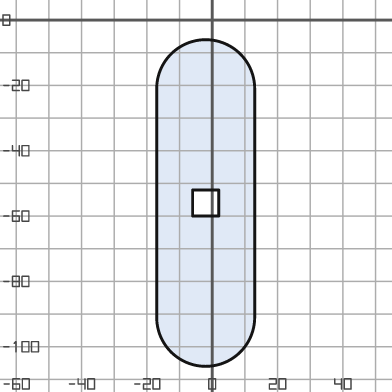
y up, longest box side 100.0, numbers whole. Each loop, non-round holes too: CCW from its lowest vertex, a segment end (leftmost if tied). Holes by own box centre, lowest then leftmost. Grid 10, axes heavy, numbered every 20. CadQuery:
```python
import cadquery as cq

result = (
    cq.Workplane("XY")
    .moveTo(-17.0, -91.0)
    .threePointArc((-2.0, -106.0), (13.0, -91.0))
    .lineTo(13.0, -21.0)
    .threePointArc((-2.0, -6.0), (-17.0, -21.0))
    .close()
    .moveTo(-6.0, -60.0)
    .lineTo(2.0, -60.0)
    .lineTo(2.0, -52.0)
    .lineTo(-6.0, -52.0)
    .close()
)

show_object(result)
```